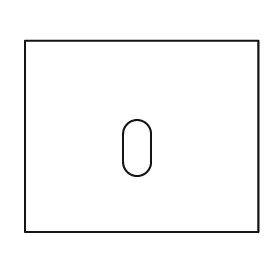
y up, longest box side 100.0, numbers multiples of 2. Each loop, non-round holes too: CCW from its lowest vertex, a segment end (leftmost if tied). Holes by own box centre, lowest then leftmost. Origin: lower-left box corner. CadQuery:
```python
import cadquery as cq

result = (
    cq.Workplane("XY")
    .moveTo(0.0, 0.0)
    .lineTo(100.0, 0.0)
    .lineTo(100.0, 82.0)
    .lineTo(0.0, 82.0)
    .close()
    .moveTo(42.0, 30.0)
    .threePointArc((48.0, 24.0), (54.0, 30.0))
    .lineTo(54.0, 42.0)
    .threePointArc((48.0, 48.0), (42.0, 42.0))
    .close()
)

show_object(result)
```